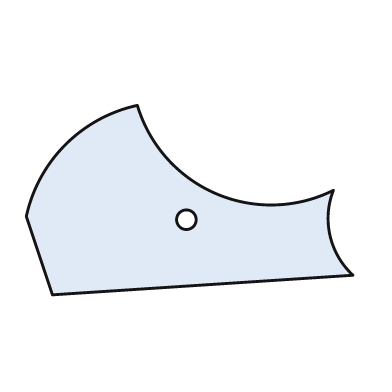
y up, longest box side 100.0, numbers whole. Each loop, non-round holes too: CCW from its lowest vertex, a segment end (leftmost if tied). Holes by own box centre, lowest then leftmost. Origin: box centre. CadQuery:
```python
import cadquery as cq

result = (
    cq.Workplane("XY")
    .moveTo(-42.0, -29.0)
    .lineTo(50.0, -23.0)
    .threePointArc((43.0, -11.0), (44.0, 3.0))
    .threePointArc((8.0, 2.0), (-16.0, 29.0))
    .threePointArc((-38.0, 17.0), (-50.0, -5.0))
    .close()
    .moveTo(-1.0, -6.0)
    .circle(3.0)
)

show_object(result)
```